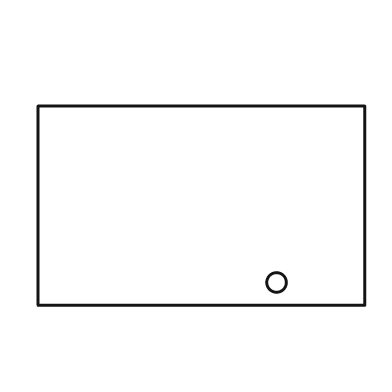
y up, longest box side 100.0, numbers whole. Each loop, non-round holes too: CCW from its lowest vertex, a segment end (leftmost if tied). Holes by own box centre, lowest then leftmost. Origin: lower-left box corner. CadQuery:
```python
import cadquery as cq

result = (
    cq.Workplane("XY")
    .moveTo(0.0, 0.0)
    .lineTo(100.0, 0.0)
    .lineTo(100.0, 61.0)
    .lineTo(0.0, 61.0)
    .close()
    .moveTo(73.0, 7.0)
    .circle(3.0)
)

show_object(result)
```